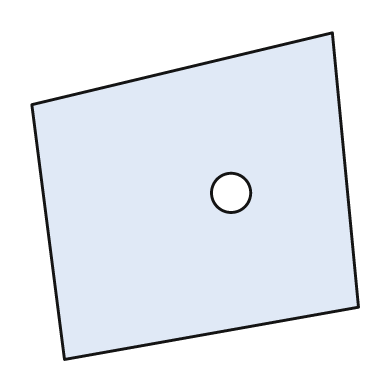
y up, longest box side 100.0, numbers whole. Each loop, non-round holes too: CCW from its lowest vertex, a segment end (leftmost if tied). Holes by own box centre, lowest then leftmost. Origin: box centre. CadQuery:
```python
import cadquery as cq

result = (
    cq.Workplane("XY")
    .moveTo(-40.0, -50.0)
    .lineTo(50.0, -34.0)
    .lineTo(42.0, 50.0)
    .lineTo(-50.0, 28.0)
    .close()
    .moveTo(11.0, 1.0)
    .circle(6.0)
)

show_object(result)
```